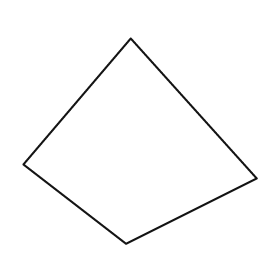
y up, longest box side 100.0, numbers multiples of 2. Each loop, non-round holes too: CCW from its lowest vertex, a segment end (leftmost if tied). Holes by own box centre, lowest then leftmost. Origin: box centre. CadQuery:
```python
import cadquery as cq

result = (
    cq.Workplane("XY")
    .moveTo(-6.0, -44.0)
    .lineTo(50.0, -16.0)
    .lineTo(-4.0, 44.0)
    .lineTo(-50.0, -10.0)
    .close()
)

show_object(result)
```